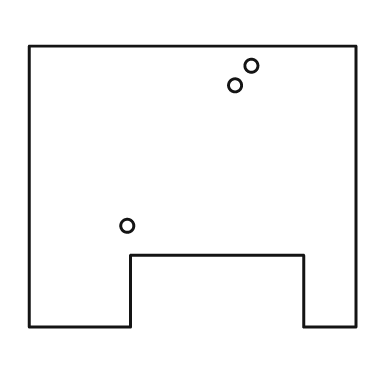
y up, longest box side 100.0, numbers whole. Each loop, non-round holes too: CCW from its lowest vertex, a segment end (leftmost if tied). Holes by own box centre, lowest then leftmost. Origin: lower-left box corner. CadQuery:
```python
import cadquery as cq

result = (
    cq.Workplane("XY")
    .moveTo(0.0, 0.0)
    .lineTo(31.0, 0.0)
    .lineTo(31.0, 22.0)
    .lineTo(84.0, 22.0)
    .lineTo(84.0, 0.0)
    .lineTo(100.0, 0.0)
    .lineTo(100.0, 86.0)
    .lineTo(0.0, 86.0)
    .close()
    .moveTo(30.0, 31.0)
    .circle(2.0)
    .moveTo(63.0, 74.0)
    .circle(2.0)
    .moveTo(68.0, 80.0)
    .circle(2.0)
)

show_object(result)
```